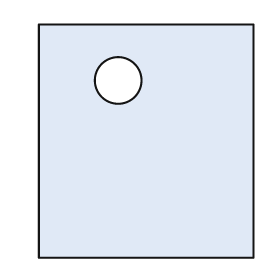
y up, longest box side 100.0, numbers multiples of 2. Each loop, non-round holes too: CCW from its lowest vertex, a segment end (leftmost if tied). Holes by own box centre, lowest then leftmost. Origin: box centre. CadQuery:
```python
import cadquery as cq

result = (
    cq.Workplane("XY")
    .moveTo(-46.0, -50.0)
    .lineTo(46.0, -50.0)
    .lineTo(46.0, 50.0)
    .lineTo(-46.0, 50.0)
    .close()
    .moveTo(-12.0, 26.0)
    .circle(10.0)
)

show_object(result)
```